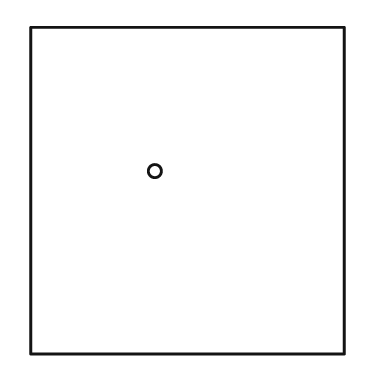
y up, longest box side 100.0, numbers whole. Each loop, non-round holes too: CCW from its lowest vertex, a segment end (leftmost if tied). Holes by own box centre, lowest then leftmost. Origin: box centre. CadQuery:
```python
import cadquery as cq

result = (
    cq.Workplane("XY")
    .moveTo(-48.0, -50.0)
    .lineTo(48.0, -50.0)
    .lineTo(48.0, 50.0)
    .lineTo(-48.0, 50.0)
    .close()
    .moveTo(-10.0, 6.0)
    .circle(2.0)
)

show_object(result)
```